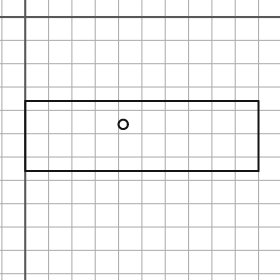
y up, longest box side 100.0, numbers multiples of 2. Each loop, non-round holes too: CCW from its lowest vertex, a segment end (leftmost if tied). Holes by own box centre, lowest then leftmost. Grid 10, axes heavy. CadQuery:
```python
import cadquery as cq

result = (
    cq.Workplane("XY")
    .moveTo(0.0, -66.0)
    .lineTo(100.0, -66.0)
    .lineTo(100.0, -36.0)
    .lineTo(0.0, -36.0)
    .close()
    .moveTo(42.0, -46.0)
    .circle(2.0)
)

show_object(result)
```